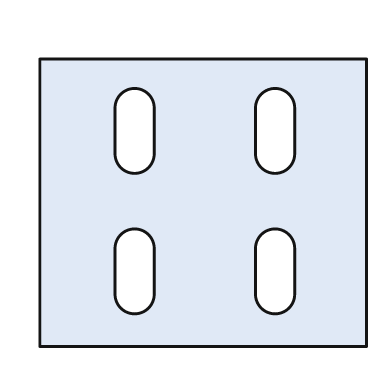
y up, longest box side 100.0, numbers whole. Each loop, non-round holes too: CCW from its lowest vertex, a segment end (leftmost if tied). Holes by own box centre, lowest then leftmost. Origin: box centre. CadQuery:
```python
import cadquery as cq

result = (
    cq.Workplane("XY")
    .moveTo(-50.0, -44.0)
    .lineTo(50.0, -44.0)
    .lineTo(50.0, 44.0)
    .lineTo(-50.0, 44.0)
    .close()
    .moveTo(-27.0, -28.0)
    .threePointArc((-21.0, -34.0), (-15.0, -28.0))
    .lineTo(-15.0, -14.0)
    .threePointArc((-21.0, -8.0), (-27.0, -14.0))
    .close()
    .moveTo(16.0, -28.0)
    .threePointArc((22.0, -34.0), (28.0, -28.0))
    .lineTo(28.0, -14.0)
    .threePointArc((22.0, -8.0), (16.0, -14.0))
    .close()
    .moveTo(-27.0, 15.0)
    .threePointArc((-21.0, 9.0), (-15.0, 15.0))
    .lineTo(-15.0, 29.0)
    .threePointArc((-21.0, 35.0), (-27.0, 29.0))
    .close()
    .moveTo(16.0, 15.0)
    .threePointArc((22.0, 9.0), (28.0, 15.0))
    .lineTo(28.0, 29.0)
    .threePointArc((22.0, 35.0), (16.0, 29.0))
    .close()
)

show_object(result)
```